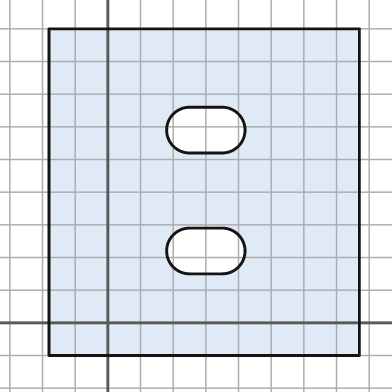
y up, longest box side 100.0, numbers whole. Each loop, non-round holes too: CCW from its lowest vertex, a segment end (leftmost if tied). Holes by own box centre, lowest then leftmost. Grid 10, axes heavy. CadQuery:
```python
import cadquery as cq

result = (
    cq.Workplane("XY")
    .moveTo(-18.0, -10.0)
    .lineTo(77.0, -10.0)
    .lineTo(77.0, 90.0)
    .lineTo(-18.0, 90.0)
    .close()
    .moveTo(25.0, 15.0)
    .lineTo(35.0, 15.0)
    .threePointArc((42.0, 22.0), (35.0, 29.0))
    .lineTo(25.0, 29.0)
    .threePointArc((18.0, 22.0), (25.0, 15.0))
    .close()
    .moveTo(25.0, 52.0)
    .lineTo(35.0, 52.0)
    .threePointArc((42.0, 59.0), (35.0, 66.0))
    .lineTo(25.0, 66.0)
    .threePointArc((18.0, 59.0), (25.0, 52.0))
    .close()
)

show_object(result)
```